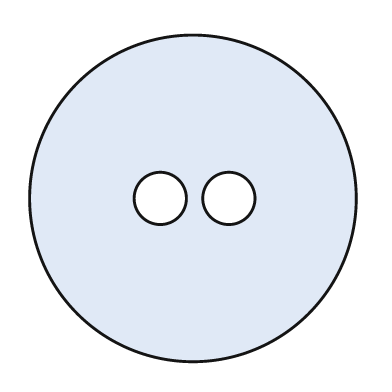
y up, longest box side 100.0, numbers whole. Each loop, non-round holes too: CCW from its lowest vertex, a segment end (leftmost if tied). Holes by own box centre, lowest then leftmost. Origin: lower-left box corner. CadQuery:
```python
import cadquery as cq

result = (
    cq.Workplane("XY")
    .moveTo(50.0, 50.0)
    .circle(50.0)
    .moveTo(40.0, 50.0)
    .circle(8.0)
    .moveTo(61.0, 50.0)
    .circle(8.0)
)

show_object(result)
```